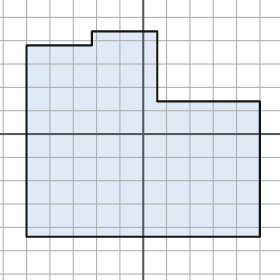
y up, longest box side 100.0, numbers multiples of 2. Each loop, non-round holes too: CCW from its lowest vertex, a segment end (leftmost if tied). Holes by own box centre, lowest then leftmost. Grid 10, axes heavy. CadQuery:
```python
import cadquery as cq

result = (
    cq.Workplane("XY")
    .moveTo(-50.0, -44.0)
    .lineTo(50.0, -44.0)
    .lineTo(50.0, 14.0)
    .lineTo(6.0, 14.0)
    .lineTo(6.0, 44.0)
    .lineTo(-22.0, 44.0)
    .lineTo(-22.0, 38.0)
    .lineTo(-50.0, 38.0)
    .close()
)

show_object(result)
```